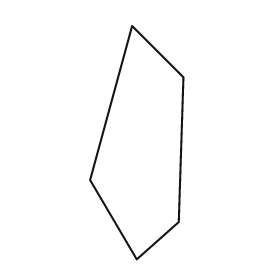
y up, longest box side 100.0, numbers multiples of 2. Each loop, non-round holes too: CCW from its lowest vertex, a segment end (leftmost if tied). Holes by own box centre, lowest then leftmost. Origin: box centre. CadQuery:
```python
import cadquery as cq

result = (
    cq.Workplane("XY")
    .moveTo(0.0, -50.0)
    .lineTo(18.0, -34.0)
    .lineTo(20.0, 28.0)
    .lineTo(-2.0, 50.0)
    .lineTo(-20.0, -16.0)
    .close()
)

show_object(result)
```